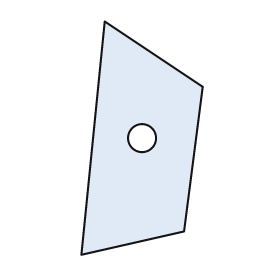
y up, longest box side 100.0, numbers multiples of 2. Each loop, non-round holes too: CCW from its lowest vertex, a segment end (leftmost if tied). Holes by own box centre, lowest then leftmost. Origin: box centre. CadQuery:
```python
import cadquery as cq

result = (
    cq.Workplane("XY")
    .moveTo(-26.0, -50.0)
    .lineTo(18.0, -40.0)
    .lineTo(26.0, 22.0)
    .lineTo(-16.0, 50.0)
    .close()
    .moveTo(0.0, 0.0)
    .circle(6.0)
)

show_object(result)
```